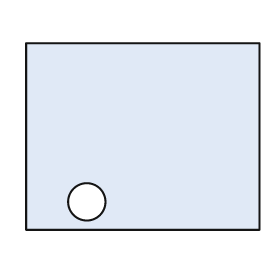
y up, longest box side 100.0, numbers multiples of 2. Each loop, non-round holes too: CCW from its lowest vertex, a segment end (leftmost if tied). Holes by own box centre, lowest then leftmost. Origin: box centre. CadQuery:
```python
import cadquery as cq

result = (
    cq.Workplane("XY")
    .moveTo(-50.0, -40.0)
    .lineTo(50.0, -40.0)
    .lineTo(50.0, 40.0)
    .lineTo(-50.0, 40.0)
    .close()
    .moveTo(-24.0, -28.0)
    .circle(8.0)
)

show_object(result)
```